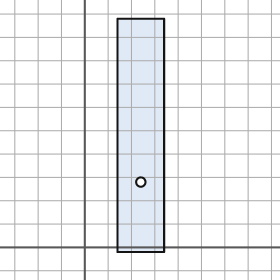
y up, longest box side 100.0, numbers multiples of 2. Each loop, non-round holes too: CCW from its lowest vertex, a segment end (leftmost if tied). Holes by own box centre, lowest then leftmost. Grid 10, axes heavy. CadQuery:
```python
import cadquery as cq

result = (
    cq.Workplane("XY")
    .moveTo(14.0, -2.0)
    .lineTo(34.0, -2.0)
    .lineTo(34.0, 98.0)
    .lineTo(14.0, 98.0)
    .close()
    .moveTo(24.0, 28.0)
    .circle(2.0)
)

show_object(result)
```